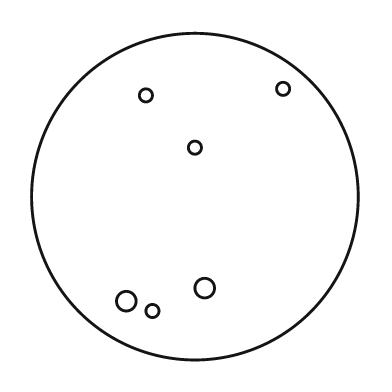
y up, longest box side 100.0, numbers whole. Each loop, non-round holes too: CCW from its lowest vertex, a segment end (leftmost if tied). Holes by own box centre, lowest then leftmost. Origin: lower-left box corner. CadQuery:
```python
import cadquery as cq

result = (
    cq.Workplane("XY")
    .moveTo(50.0, 50.0)
    .circle(50.0)
    .moveTo(37.0, 15.0)
    .circle(2.0)
    .moveTo(29.0, 18.0)
    .circle(3.0)
    .moveTo(53.0, 22.0)
    .circle(3.0)
    .moveTo(50.0, 65.0)
    .circle(2.0)
    .moveTo(35.0, 81.0)
    .circle(2.0)
    .moveTo(77.0, 83.0)
    .circle(2.0)
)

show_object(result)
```